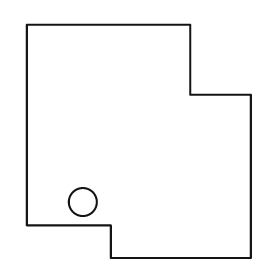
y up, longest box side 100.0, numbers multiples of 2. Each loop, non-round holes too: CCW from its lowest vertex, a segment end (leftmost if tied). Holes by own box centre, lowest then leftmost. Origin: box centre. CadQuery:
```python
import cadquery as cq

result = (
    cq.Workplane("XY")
    .moveTo(-12.0, -50.0)
    .lineTo(48.0, -50.0)
    .lineTo(48.0, 20.0)
    .lineTo(22.0, 20.0)
    .lineTo(22.0, 50.0)
    .lineTo(-48.0, 50.0)
    .lineTo(-48.0, -36.0)
    .lineTo(-12.0, -36.0)
    .close()
    .moveTo(-24.0, -26.0)
    .circle(6.0)
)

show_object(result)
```